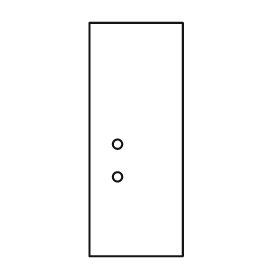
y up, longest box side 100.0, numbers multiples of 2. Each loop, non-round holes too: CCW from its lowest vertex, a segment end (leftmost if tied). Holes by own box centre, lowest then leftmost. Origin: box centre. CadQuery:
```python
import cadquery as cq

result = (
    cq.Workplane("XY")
    .moveTo(-20.0, -50.0)
    .lineTo(20.0, -50.0)
    .lineTo(20.0, 50.0)
    .lineTo(-20.0, 50.0)
    .close()
    .moveTo(-8.0, -16.0)
    .circle(2.0)
    .moveTo(-8.0, -2.0)
    .circle(2.0)
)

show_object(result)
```